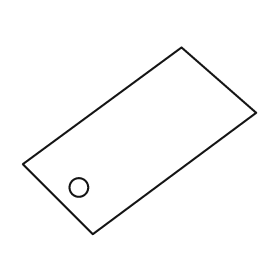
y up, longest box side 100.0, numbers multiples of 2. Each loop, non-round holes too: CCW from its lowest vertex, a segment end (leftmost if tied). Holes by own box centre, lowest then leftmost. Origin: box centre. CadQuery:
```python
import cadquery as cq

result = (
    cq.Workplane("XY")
    .moveTo(-20.0, -40.0)
    .lineTo(50.0, 12.0)
    .lineTo(18.0, 40.0)
    .lineTo(-50.0, -10.0)
    .close()
    .moveTo(-26.0, -20.0)
    .circle(4.0)
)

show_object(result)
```